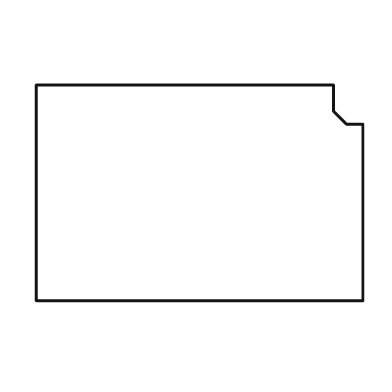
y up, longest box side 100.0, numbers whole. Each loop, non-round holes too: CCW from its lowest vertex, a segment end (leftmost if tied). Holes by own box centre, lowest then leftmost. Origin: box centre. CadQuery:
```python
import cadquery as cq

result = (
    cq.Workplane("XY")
    .moveTo(-50.0, -33.0)
    .lineTo(50.0, -33.0)
    .lineTo(50.0, 21.0)
    .lineTo(45.0, 21.0)
    .lineTo(41.0, 25.0)
    .lineTo(41.0, 33.0)
    .lineTo(-50.0, 33.0)
    .close()
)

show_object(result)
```